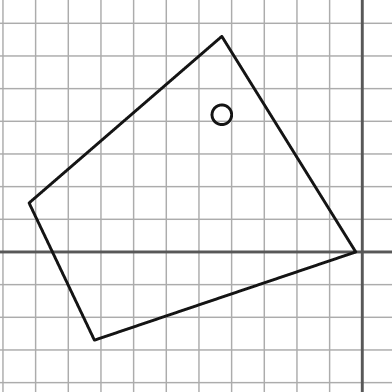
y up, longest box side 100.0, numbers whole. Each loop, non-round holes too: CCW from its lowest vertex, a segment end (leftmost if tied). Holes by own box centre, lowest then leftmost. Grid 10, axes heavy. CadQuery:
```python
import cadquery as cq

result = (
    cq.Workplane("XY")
    .moveTo(-82.0, -27.0)
    .lineTo(-2.0, 0.0)
    .lineTo(-43.0, 66.0)
    .lineTo(-102.0, 15.0)
    .close()
    .moveTo(-43.0, 42.0)
    .circle(3.0)
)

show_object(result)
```